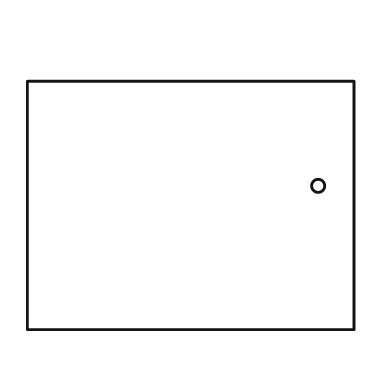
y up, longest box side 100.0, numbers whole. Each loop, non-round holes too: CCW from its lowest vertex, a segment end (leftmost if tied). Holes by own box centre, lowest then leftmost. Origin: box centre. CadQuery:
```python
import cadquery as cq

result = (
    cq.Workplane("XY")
    .moveTo(-50.0, -38.0)
    .lineTo(50.0, -38.0)
    .lineTo(50.0, 38.0)
    .lineTo(-50.0, 38.0)
    .close()
    .moveTo(39.0, 6.0)
    .circle(2.0)
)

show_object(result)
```